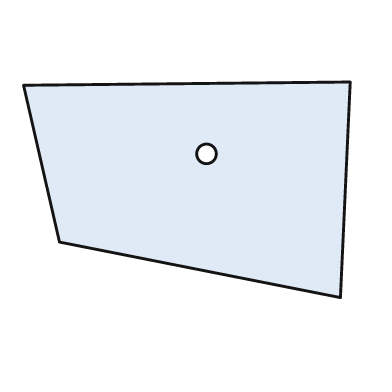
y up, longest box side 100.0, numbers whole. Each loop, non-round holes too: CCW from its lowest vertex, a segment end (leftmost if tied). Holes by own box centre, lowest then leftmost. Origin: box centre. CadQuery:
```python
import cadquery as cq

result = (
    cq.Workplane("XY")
    .moveTo(47.0, -33.0)
    .lineTo(50.0, 33.0)
    .lineTo(-50.0, 32.0)
    .lineTo(-39.0, -16.0)
    .close()
    .moveTo(6.0, 11.0)
    .circle(3.0)
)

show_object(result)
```